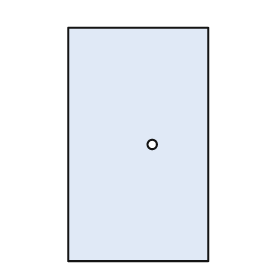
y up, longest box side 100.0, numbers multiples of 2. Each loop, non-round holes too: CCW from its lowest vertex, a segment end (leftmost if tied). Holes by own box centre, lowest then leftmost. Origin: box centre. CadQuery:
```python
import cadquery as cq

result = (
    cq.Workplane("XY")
    .moveTo(-30.0, -50.0)
    .lineTo(30.0, -50.0)
    .lineTo(30.0, 50.0)
    .lineTo(-30.0, 50.0)
    .close()
    .moveTo(6.0, 0.0)
    .circle(2.0)
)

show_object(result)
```